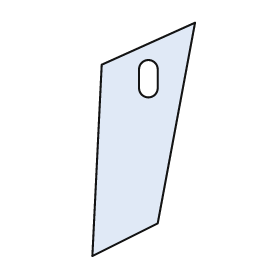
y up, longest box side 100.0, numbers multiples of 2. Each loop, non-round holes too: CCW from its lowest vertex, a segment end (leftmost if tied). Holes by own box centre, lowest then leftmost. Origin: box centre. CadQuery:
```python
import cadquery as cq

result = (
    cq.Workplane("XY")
    .moveTo(-22.0, -50.0)
    .lineTo(6.0, -36.0)
    .lineTo(22.0, 50.0)
    .lineTo(-18.0, 32.0)
    .close()
    .moveTo(-2.0, 22.0)
    .threePointArc((2.0, 18.0), (6.0, 22.0))
    .lineTo(6.0, 30.0)
    .threePointArc((2.0, 34.0), (-2.0, 30.0))
    .close()
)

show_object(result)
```